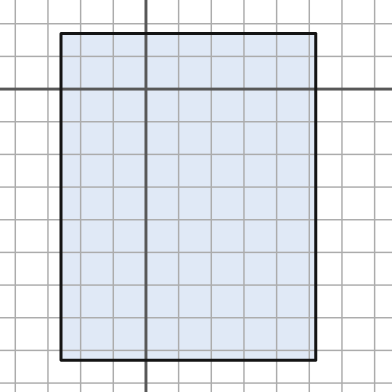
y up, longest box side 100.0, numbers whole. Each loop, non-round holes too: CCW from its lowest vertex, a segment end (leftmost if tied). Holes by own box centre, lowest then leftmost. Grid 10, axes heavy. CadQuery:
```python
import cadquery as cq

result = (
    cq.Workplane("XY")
    .moveTo(-26.0, -83.0)
    .lineTo(52.0, -83.0)
    .lineTo(52.0, 17.0)
    .lineTo(-26.0, 17.0)
    .close()
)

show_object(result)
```